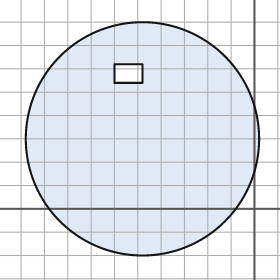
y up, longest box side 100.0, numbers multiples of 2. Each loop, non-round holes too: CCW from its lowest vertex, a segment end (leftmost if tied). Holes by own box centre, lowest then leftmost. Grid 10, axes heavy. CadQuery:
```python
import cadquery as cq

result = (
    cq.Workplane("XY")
    .moveTo(-48.0, 30.0)
    .circle(50.0)
    .moveTo(-60.0, 54.0)
    .lineTo(-48.0, 54.0)
    .lineTo(-48.0, 62.0)
    .lineTo(-60.0, 62.0)
    .close()
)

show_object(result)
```